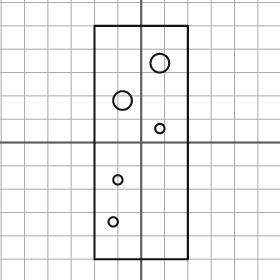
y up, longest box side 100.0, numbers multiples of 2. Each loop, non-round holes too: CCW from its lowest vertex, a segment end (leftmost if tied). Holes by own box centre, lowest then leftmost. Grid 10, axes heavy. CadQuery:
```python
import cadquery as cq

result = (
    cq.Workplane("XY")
    .moveTo(-20.0, -50.0)
    .lineTo(20.0, -50.0)
    .lineTo(20.0, 50.0)
    .lineTo(-20.0, 50.0)
    .close()
    .moveTo(-12.0, -34.0)
    .circle(2.0)
    .moveTo(-10.0, -16.0)
    .circle(2.0)
    .moveTo(8.0, 6.0)
    .circle(2.0)
    .moveTo(-8.0, 18.0)
    .circle(4.0)
    .moveTo(8.0, 34.0)
    .circle(4.0)
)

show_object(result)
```